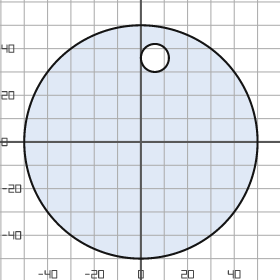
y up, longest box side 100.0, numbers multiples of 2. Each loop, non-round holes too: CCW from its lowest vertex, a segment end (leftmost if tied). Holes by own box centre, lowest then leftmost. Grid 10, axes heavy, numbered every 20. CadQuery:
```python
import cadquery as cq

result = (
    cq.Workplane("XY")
    .moveTo(0.0, 0.0)
    .circle(50.0)
    .moveTo(6.0, 36.0)
    .circle(6.0)
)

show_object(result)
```